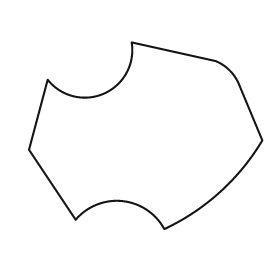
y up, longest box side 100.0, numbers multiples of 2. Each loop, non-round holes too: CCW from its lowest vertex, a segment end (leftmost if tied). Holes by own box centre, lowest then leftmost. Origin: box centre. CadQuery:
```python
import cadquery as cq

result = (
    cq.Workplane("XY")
    .moveTo(8.0, -40.0)
    .threePointArc((32.0, -24.0), (50.0, -2.0))
    .lineTo(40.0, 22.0)
    .threePointArc((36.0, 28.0), (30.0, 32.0))
    .lineTo(-6.0, 40.0)
    .threePointArc((-18.0, 18.0), (-42.0, 24.0))
    .lineTo(-50.0, -6.0)
    .lineTo(-30.0, -36.0)
    .threePointArc((-10.0, -28.0), (8.0, -40.0))
    .close()
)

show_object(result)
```